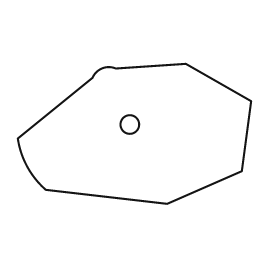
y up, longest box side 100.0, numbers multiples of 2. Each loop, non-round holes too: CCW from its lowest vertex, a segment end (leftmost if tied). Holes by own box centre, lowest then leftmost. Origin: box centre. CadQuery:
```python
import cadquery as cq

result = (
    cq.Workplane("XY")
    .moveTo(14.0, -30.0)
    .lineTo(46.0, -16.0)
    .lineTo(50.0, 14.0)
    .lineTo(22.0, 30.0)
    .lineTo(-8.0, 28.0)
    .threePointArc((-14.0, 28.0), (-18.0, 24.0))
    .lineTo(-50.0, -2.0)
    .threePointArc((-46.0, -14.0), (-38.0, -24.0))
    .close()
    .moveTo(-2.0, 4.0)
    .circle(4.0)
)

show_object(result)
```